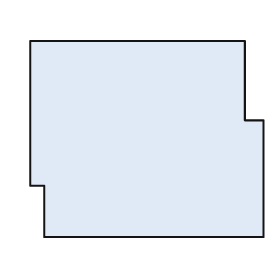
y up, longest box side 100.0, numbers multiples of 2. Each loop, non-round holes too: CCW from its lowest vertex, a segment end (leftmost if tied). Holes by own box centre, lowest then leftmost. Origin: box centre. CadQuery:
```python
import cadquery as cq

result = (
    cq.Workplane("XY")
    .moveTo(-44.0, -42.0)
    .lineTo(50.0, -42.0)
    .lineTo(50.0, 8.0)
    .lineTo(42.0, 8.0)
    .lineTo(42.0, 42.0)
    .lineTo(-50.0, 42.0)
    .lineTo(-50.0, -20.0)
    .lineTo(-44.0, -20.0)
    .close()
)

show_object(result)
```